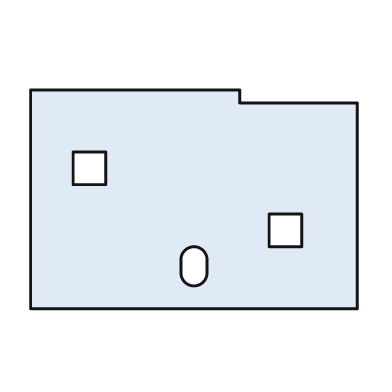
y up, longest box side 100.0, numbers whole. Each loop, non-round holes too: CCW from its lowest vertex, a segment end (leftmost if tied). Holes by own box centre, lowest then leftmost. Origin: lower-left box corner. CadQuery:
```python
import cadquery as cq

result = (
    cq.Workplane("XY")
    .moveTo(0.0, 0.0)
    .lineTo(100.0, 0.0)
    .lineTo(100.0, 63.0)
    .lineTo(64.0, 63.0)
    .lineTo(64.0, 67.0)
    .lineTo(0.0, 67.0)
    .close()
    .moveTo(46.0, 11.0)
    .threePointArc((50.0, 7.0), (54.0, 11.0))
    .lineTo(54.0, 15.0)
    .threePointArc((50.0, 19.0), (46.0, 15.0))
    .close()
    .moveTo(73.0, 19.0)
    .lineTo(83.0, 19.0)
    .lineTo(83.0, 29.0)
    .lineTo(73.0, 29.0)
    .close()
    .moveTo(13.0, 38.0)
    .lineTo(23.0, 38.0)
    .lineTo(23.0, 48.0)
    .lineTo(13.0, 48.0)
    .close()
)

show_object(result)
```